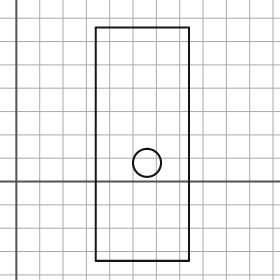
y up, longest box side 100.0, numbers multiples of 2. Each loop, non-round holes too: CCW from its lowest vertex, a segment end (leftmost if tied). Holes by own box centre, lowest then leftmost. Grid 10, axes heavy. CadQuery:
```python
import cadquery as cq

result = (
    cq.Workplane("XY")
    .moveTo(34.0, -34.0)
    .lineTo(74.0, -34.0)
    .lineTo(74.0, 66.0)
    .lineTo(34.0, 66.0)
    .close()
    .moveTo(56.0, 8.0)
    .circle(6.0)
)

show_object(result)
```